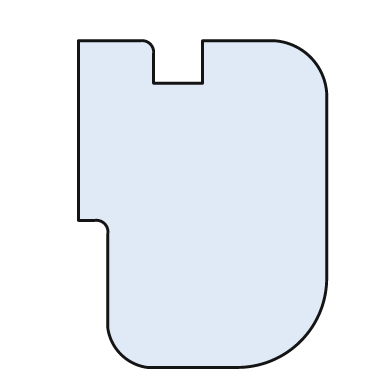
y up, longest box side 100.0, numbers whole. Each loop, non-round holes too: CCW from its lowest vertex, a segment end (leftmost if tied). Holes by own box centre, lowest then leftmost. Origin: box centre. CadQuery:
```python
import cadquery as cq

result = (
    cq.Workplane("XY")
    .moveTo(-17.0, -50.0)
    .lineTo(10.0, -50.0)
    .threePointArc((30.0, -42.0), (38.0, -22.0))
    .lineTo(38.0, 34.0)
    .threePointArc((33.0, 45.0), (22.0, 50.0))
    .lineTo(0.0, 50.0)
    .lineTo(0.0, 37.0)
    .lineTo(-15.0, 37.0)
    .lineTo(-15.0, 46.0)
    .threePointArc((-16.0, 49.0), (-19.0, 50.0))
    .lineTo(-38.0, 50.0)
    .lineTo(-38.0, -5.0)
    .lineTo(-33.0, -5.0)
    .threePointArc((-30.0, -6.0), (-29.0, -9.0))
    .lineTo(-29.0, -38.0)
    .threePointArc((-25.0, -46.0), (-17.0, -50.0))
    .close()
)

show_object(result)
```